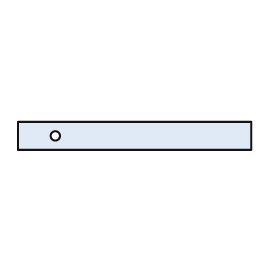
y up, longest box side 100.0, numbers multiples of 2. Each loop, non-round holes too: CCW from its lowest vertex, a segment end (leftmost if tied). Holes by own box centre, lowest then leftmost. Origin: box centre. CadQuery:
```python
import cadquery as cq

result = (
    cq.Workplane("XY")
    .moveTo(-50.0, -6.0)
    .lineTo(50.0, -6.0)
    .lineTo(50.0, 6.0)
    .lineTo(-50.0, 6.0)
    .close()
    .moveTo(-34.0, 0.0)
    .circle(2.0)
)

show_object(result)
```